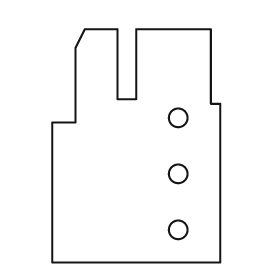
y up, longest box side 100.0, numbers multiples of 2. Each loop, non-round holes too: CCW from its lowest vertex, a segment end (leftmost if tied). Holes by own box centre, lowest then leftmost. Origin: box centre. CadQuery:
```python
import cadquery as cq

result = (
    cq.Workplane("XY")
    .moveTo(-36.0, -50.0)
    .lineTo(36.0, -50.0)
    .lineTo(36.0, 18.0)
    .lineTo(32.0, 18.0)
    .lineTo(32.0, 50.0)
    .lineTo(0.0, 50.0)
    .lineTo(0.0, 20.0)
    .lineTo(-8.0, 20.0)
    .lineTo(-8.0, 50.0)
    .lineTo(-22.0, 50.0)
    .lineTo(-26.0, 42.0)
    .lineTo(-26.0, 10.0)
    .lineTo(-36.0, 10.0)
    .close()
    .moveTo(18.0, -36.0)
    .circle(4.0)
    .moveTo(18.0, -12.0)
    .circle(4.0)
    .moveTo(18.0, 12.0)
    .circle(4.0)
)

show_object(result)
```